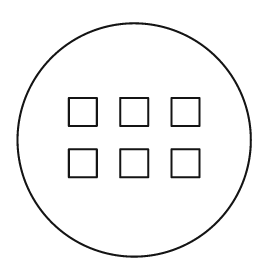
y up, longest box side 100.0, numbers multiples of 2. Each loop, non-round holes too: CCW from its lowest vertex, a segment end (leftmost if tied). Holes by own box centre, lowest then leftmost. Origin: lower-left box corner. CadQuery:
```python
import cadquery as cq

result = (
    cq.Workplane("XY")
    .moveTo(50.0, 50.0)
    .circle(50.0)
    .moveTo(22.0, 34.0)
    .lineTo(34.0, 34.0)
    .lineTo(34.0, 46.0)
    .lineTo(22.0, 46.0)
    .close()
    .moveTo(44.0, 34.0)
    .lineTo(56.0, 34.0)
    .lineTo(56.0, 46.0)
    .lineTo(44.0, 46.0)
    .close()
    .moveTo(66.0, 34.0)
    .lineTo(78.0, 34.0)
    .lineTo(78.0, 46.0)
    .lineTo(66.0, 46.0)
    .close()
    .moveTo(22.0, 56.0)
    .lineTo(34.0, 56.0)
    .lineTo(34.0, 68.0)
    .lineTo(22.0, 68.0)
    .close()
    .moveTo(44.0, 56.0)
    .lineTo(56.0, 56.0)
    .lineTo(56.0, 68.0)
    .lineTo(44.0, 68.0)
    .close()
    .moveTo(66.0, 56.0)
    .lineTo(78.0, 56.0)
    .lineTo(78.0, 68.0)
    .lineTo(66.0, 68.0)
    .close()
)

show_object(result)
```